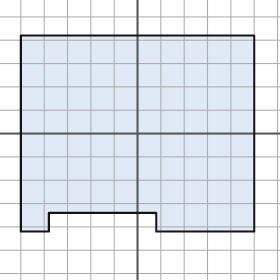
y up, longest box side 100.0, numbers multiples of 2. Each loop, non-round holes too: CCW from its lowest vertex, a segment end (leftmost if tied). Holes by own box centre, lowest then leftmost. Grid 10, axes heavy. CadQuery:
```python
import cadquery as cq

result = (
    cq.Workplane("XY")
    .moveTo(-50.0, -42.0)
    .lineTo(-38.0, -42.0)
    .lineTo(-38.0, -34.0)
    .lineTo(8.0, -34.0)
    .lineTo(8.0, -42.0)
    .lineTo(50.0, -42.0)
    .lineTo(50.0, 42.0)
    .lineTo(-50.0, 42.0)
    .close()
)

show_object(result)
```